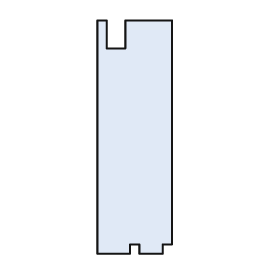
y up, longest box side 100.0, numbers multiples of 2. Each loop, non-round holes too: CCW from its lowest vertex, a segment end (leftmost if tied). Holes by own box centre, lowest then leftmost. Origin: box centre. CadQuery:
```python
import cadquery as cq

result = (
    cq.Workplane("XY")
    .moveTo(-16.0, -50.0)
    .lineTo(-2.0, -50.0)
    .lineTo(-2.0, -46.0)
    .lineTo(2.0, -46.0)
    .lineTo(2.0, -50.0)
    .lineTo(12.0, -50.0)
    .lineTo(12.0, -46.0)
    .lineTo(16.0, -46.0)
    .lineTo(16.0, 50.0)
    .lineTo(-4.0, 50.0)
    .lineTo(-4.0, 38.0)
    .lineTo(-12.0, 38.0)
    .lineTo(-12.0, 50.0)
    .lineTo(-16.0, 50.0)
    .close()
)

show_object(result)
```